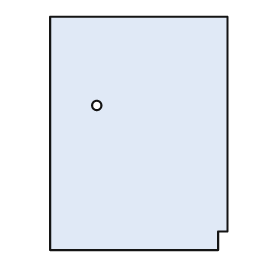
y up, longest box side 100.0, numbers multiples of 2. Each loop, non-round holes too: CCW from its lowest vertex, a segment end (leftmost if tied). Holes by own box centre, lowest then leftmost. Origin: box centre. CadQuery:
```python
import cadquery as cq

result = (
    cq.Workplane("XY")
    .moveTo(-38.0, -50.0)
    .lineTo(34.0, -50.0)
    .lineTo(34.0, -42.0)
    .lineTo(38.0, -42.0)
    .lineTo(38.0, 50.0)
    .lineTo(-38.0, 50.0)
    .close()
    .moveTo(-18.0, 12.0)
    .circle(2.0)
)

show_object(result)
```